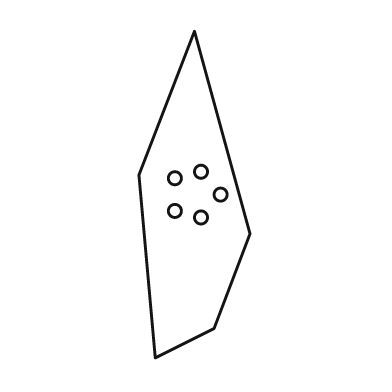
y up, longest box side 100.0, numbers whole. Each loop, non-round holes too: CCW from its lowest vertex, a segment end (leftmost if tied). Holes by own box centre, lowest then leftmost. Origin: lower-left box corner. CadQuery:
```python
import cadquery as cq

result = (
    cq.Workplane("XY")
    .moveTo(5.0, 0.0)
    .lineTo(23.0, 9.0)
    .lineTo(34.0, 38.0)
    .lineTo(17.0, 100.0)
    .lineTo(0.0, 56.0)
    .close()
    .moveTo(19.0, 43.0)
    .circle(2.0)
    .moveTo(11.0, 45.0)
    .circle(2.0)
    .moveTo(25.0, 50.0)
    .circle(2.0)
    .moveTo(11.0, 55.0)
    .circle(2.0)
    .moveTo(19.0, 57.0)
    .circle(2.0)
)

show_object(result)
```